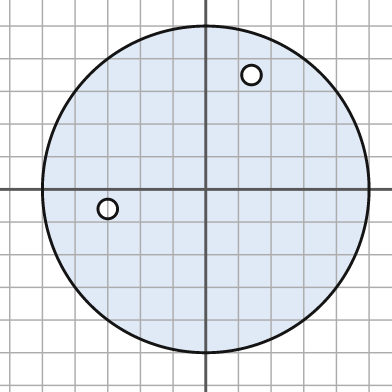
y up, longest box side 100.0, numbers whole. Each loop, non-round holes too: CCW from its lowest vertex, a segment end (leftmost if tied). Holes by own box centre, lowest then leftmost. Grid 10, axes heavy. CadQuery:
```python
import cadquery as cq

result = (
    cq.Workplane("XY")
    .moveTo(0.0, 0.0)
    .circle(50.0)
    .moveTo(-30.0, -6.0)
    .circle(3.0)
    .moveTo(14.0, 35.0)
    .circle(3.0)
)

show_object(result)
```